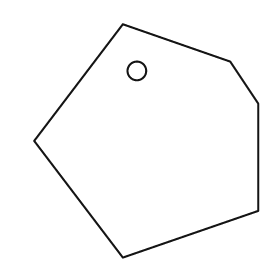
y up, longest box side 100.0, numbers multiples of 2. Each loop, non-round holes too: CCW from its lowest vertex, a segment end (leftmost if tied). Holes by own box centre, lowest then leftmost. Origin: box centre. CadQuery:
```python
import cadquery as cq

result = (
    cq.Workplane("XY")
    .moveTo(-10.0, -50.0)
    .lineTo(48.0, -30.0)
    .lineTo(48.0, 16.0)
    .lineTo(36.0, 34.0)
    .lineTo(-10.0, 50.0)
    .lineTo(-48.0, 0.0)
    .close()
    .moveTo(-4.0, 30.0)
    .circle(4.0)
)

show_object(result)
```